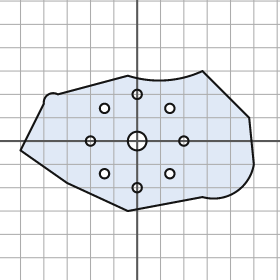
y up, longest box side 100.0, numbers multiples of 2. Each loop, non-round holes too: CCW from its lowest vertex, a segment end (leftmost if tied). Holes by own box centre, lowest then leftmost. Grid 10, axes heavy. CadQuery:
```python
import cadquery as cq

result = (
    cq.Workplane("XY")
    .moveTo(-4.0, -30.0)
    .lineTo(28.0, -24.0)
    .threePointArc((42.0, -22.0), (50.0, -10.0))
    .lineTo(48.0, 10.0)
    .lineTo(28.0, 30.0)
    .threePointArc((12.0, 26.0), (-4.0, 28.0))
    .lineTo(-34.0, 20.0)
    .threePointArc((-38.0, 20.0), (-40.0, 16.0))
    .lineTo(-50.0, -4.0)
    .lineTo(-30.0, -18.0)
    .close()
    .moveTo(0.0, -20.0)
    .circle(2.0)
    .moveTo(-14.0, -14.0)
    .circle(2.0)
    .moveTo(14.0, -14.0)
    .circle(2.0)
    .moveTo(-20.0, 0.0)
    .circle(2.0)
    .moveTo(0.0, 0.0)
    .circle(4.0)
    .moveTo(20.0, 0.0)
    .circle(2.0)
    .moveTo(-14.0, 14.0)
    .circle(2.0)
    .moveTo(14.0, 14.0)
    .circle(2.0)
    .moveTo(0.0, 20.0)
    .circle(2.0)
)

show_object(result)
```